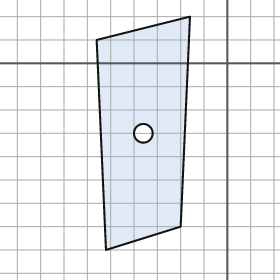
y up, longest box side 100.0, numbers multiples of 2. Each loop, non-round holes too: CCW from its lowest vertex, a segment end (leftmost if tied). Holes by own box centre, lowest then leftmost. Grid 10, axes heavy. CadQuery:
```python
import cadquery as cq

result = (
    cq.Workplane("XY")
    .moveTo(-52.0, -80.0)
    .lineTo(-20.0, -70.0)
    .lineTo(-16.0, 20.0)
    .lineTo(-56.0, 10.0)
    .close()
    .moveTo(-36.0, -30.0)
    .circle(4.0)
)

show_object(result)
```